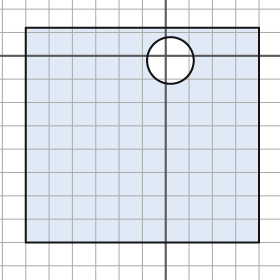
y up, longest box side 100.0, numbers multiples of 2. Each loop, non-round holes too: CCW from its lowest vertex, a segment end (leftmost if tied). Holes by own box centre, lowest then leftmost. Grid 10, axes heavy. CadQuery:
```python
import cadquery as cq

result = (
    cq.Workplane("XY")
    .moveTo(-60.0, -80.0)
    .lineTo(40.0, -80.0)
    .lineTo(40.0, 12.0)
    .lineTo(-60.0, 12.0)
    .close()
    .moveTo(2.0, -2.0)
    .circle(10.0)
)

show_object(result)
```